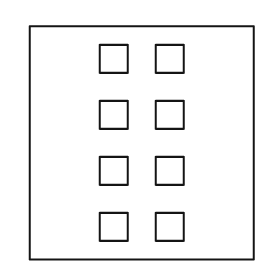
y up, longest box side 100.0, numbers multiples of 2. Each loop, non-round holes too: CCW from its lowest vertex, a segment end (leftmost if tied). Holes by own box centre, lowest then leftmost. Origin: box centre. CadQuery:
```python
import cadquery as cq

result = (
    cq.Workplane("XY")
    .moveTo(-48.0, -50.0)
    .lineTo(48.0, -50.0)
    .lineTo(48.0, 50.0)
    .lineTo(-48.0, 50.0)
    .close()
    .moveTo(-18.0, -42.0)
    .lineTo(-6.0, -42.0)
    .lineTo(-6.0, -30.0)
    .lineTo(-18.0, -30.0)
    .close()
    .moveTo(6.0, -42.0)
    .lineTo(18.0, -42.0)
    .lineTo(18.0, -30.0)
    .lineTo(6.0, -30.0)
    .close()
    .moveTo(-18.0, -18.0)
    .lineTo(-6.0, -18.0)
    .lineTo(-6.0, -6.0)
    .lineTo(-18.0, -6.0)
    .close()
    .moveTo(6.0, -18.0)
    .lineTo(18.0, -18.0)
    .lineTo(18.0, -6.0)
    .lineTo(6.0, -6.0)
    .close()
    .moveTo(-18.0, 6.0)
    .lineTo(-6.0, 6.0)
    .lineTo(-6.0, 18.0)
    .lineTo(-18.0, 18.0)
    .close()
    .moveTo(6.0, 6.0)
    .lineTo(18.0, 6.0)
    .lineTo(18.0, 18.0)
    .lineTo(6.0, 18.0)
    .close()
    .moveTo(-18.0, 30.0)
    .lineTo(-6.0, 30.0)
    .lineTo(-6.0, 42.0)
    .lineTo(-18.0, 42.0)
    .close()
    .moveTo(6.0, 30.0)
    .lineTo(18.0, 30.0)
    .lineTo(18.0, 42.0)
    .lineTo(6.0, 42.0)
    .close()
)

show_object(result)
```